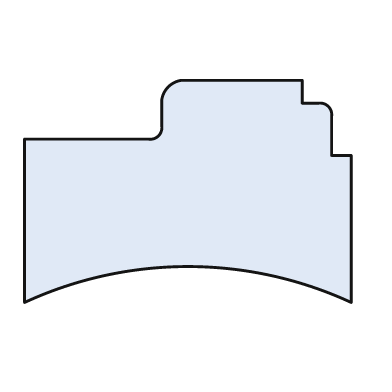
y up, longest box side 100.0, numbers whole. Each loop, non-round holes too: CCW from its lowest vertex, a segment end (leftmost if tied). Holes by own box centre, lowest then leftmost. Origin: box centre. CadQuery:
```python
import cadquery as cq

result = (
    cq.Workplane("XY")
    .moveTo(-50.0, -34.0)
    .threePointArc((0.0, -23.0), (50.0, -34.0))
    .lineTo(50.0, 11.0)
    .lineTo(44.0, 11.0)
    .lineTo(44.0, 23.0)
    .threePointArc((43.0, 26.0), (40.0, 27.0))
    .lineTo(35.0, 27.0)
    .lineTo(35.0, 34.0)
    .lineTo(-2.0, 34.0)
    .threePointArc((-6.0, 32.0), (-8.0, 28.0))
    .lineTo(-8.0, 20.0)
    .threePointArc((-9.0, 17.0), (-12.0, 16.0))
    .lineTo(-50.0, 16.0)
    .close()
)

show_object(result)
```